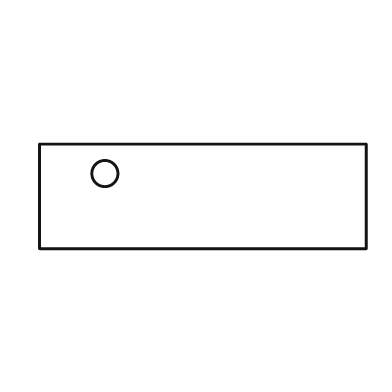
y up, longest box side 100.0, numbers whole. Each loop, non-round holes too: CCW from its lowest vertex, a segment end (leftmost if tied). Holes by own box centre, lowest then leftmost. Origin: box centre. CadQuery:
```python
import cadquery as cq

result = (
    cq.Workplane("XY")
    .moveTo(-50.0, -16.0)
    .lineTo(50.0, -16.0)
    .lineTo(50.0, 16.0)
    .lineTo(-50.0, 16.0)
    .close()
    .moveTo(-30.0, 7.0)
    .circle(4.0)
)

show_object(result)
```